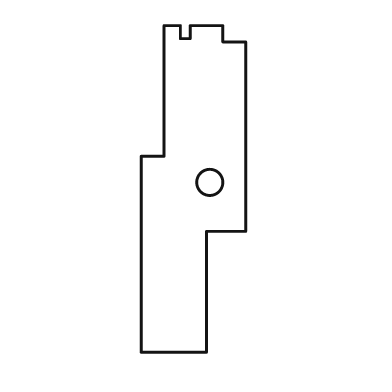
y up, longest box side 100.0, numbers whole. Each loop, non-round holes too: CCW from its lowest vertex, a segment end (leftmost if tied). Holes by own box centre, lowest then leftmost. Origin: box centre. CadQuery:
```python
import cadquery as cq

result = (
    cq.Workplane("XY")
    .moveTo(-16.0, -50.0)
    .lineTo(4.0, -50.0)
    .lineTo(4.0, -13.0)
    .lineTo(16.0, -13.0)
    .lineTo(16.0, 45.0)
    .lineTo(9.0, 45.0)
    .lineTo(9.0, 50.0)
    .lineTo(-1.0, 50.0)
    .lineTo(-1.0, 46.0)
    .lineTo(-4.0, 46.0)
    .lineTo(-4.0, 50.0)
    .lineTo(-9.0, 50.0)
    .lineTo(-9.0, 10.0)
    .lineTo(-16.0, 10.0)
    .close()
    .moveTo(5.0, 2.0)
    .circle(4.0)
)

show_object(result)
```